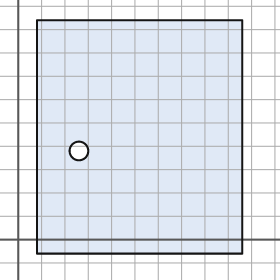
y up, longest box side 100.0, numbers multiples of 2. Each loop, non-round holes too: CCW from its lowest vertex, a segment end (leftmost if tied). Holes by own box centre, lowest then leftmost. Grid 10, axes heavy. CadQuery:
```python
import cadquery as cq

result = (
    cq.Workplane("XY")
    .moveTo(8.0, -6.0)
    .lineTo(96.0, -6.0)
    .lineTo(96.0, 94.0)
    .lineTo(8.0, 94.0)
    .close()
    .moveTo(26.0, 38.0)
    .circle(4.0)
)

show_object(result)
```